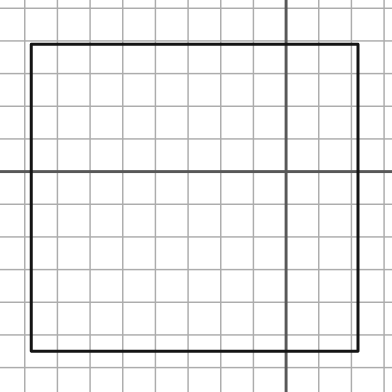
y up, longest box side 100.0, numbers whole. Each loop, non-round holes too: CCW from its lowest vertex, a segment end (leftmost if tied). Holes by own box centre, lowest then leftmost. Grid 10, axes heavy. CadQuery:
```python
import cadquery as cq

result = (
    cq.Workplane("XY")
    .moveTo(-78.0, -55.0)
    .lineTo(22.0, -55.0)
    .lineTo(22.0, 39.0)
    .lineTo(-78.0, 39.0)
    .close()
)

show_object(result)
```